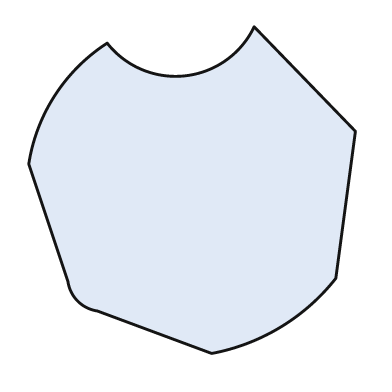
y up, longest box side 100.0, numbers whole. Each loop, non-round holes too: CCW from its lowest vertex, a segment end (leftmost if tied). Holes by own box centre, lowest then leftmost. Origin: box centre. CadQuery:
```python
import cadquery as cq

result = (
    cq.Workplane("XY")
    .moveTo(6.0, -50.0)
    .threePointArc((27.0, -42.0), (44.0, -27.0))
    .lineTo(50.0, 18.0)
    .lineTo(19.0, 50.0)
    .threePointArc((-2.0, 35.0), (-26.0, 45.0))
    .threePointArc((-42.0, 29.0), (-50.0, 8.0))
    .lineTo(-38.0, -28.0)
    .threePointArc((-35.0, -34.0), (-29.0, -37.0))
    .close()
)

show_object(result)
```